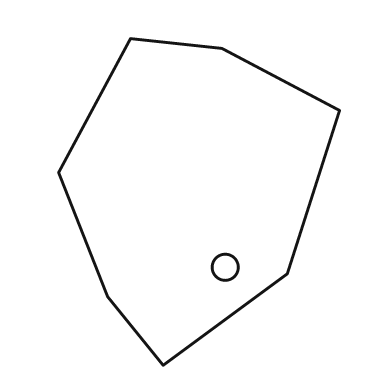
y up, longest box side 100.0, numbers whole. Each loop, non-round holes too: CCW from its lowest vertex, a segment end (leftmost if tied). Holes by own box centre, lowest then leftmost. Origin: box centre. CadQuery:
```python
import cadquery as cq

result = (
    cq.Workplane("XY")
    .moveTo(-11.0, -50.0)
    .lineTo(27.0, -22.0)
    .lineTo(43.0, 28.0)
    .lineTo(7.0, 47.0)
    .lineTo(-21.0, 50.0)
    .lineTo(-43.0, 9.0)
    .lineTo(-28.0, -29.0)
    .close()
    .moveTo(8.0, -20.0)
    .circle(4.0)
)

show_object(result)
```